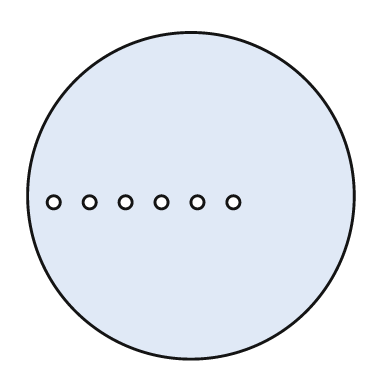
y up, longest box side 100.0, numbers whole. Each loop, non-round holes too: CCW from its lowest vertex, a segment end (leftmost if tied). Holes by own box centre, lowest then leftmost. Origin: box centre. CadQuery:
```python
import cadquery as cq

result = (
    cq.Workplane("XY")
    .moveTo(0.0, 0.0)
    .circle(50.0)
    .moveTo(-42.0, -2.0)
    .circle(2.0)
    .moveTo(-31.0, -2.0)
    .circle(2.0)
    .moveTo(-20.0, -2.0)
    .circle(2.0)
    .moveTo(-9.0, -2.0)
    .circle(2.0)
    .moveTo(2.0, -2.0)
    .circle(2.0)
    .moveTo(13.0, -2.0)
    .circle(2.0)
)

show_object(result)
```